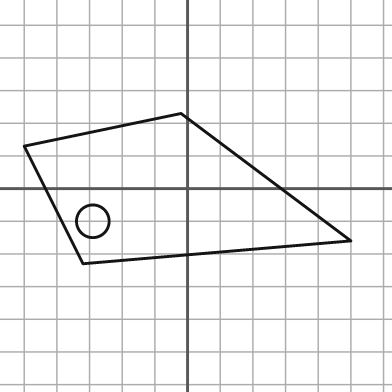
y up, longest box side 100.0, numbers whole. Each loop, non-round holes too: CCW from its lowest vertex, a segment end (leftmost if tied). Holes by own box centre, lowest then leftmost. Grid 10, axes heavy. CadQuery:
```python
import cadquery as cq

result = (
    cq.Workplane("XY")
    .moveTo(-32.0, -23.0)
    .lineTo(50.0, -16.0)
    .lineTo(-2.0, 23.0)
    .lineTo(-50.0, 13.0)
    .close()
    .moveTo(-29.0, -10.0)
    .circle(5.0)
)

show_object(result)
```